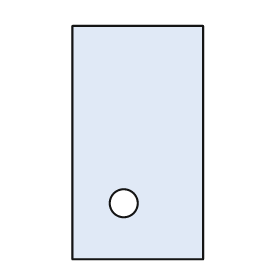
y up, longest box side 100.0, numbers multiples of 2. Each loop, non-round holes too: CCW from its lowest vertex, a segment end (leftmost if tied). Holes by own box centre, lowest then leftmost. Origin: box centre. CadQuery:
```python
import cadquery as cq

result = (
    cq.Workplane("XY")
    .moveTo(-28.0, -50.0)
    .lineTo(28.0, -50.0)
    .lineTo(28.0, 50.0)
    .lineTo(-28.0, 50.0)
    .close()
    .moveTo(-6.0, -26.0)
    .circle(6.0)
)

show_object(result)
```